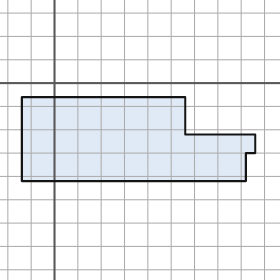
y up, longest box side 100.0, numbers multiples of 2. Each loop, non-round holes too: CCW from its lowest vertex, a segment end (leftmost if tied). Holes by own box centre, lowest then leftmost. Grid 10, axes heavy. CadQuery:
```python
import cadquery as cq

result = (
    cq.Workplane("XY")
    .moveTo(-14.0, -42.0)
    .lineTo(82.0, -42.0)
    .lineTo(82.0, -30.0)
    .lineTo(86.0, -30.0)
    .lineTo(86.0, -22.0)
    .lineTo(56.0, -22.0)
    .lineTo(56.0, -6.0)
    .lineTo(-14.0, -6.0)
    .close()
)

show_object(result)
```